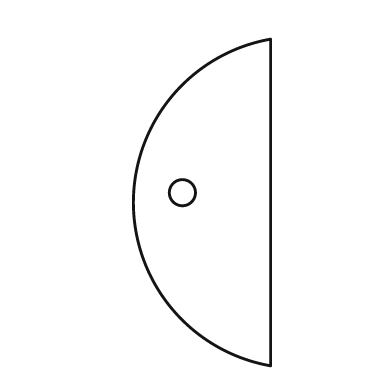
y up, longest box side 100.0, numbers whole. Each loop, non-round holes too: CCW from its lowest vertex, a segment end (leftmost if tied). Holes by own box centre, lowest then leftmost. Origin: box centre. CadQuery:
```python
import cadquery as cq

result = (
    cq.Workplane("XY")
    .moveTo(21.0, -50.0)
    .lineTo(21.0, 50.0)
    .threePointArc((-21.0, 0.0), (21.0, -50.0))
    .close()
    .moveTo(-6.0, 3.0)
    .circle(4.0)
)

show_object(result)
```